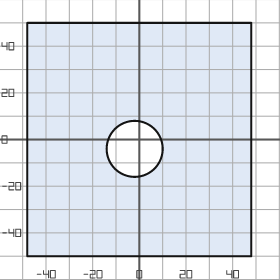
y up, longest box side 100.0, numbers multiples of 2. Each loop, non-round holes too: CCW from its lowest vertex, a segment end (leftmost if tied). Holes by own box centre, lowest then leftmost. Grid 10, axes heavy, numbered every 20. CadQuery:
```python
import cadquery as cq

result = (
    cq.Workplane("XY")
    .moveTo(-48.0, -50.0)
    .lineTo(48.0, -50.0)
    .lineTo(48.0, 50.0)
    .lineTo(-48.0, 50.0)
    .close()
    .moveTo(-2.0, -4.0)
    .circle(12.0)
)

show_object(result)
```